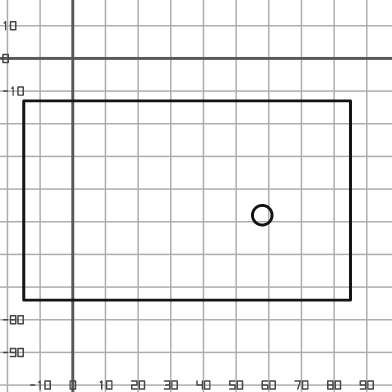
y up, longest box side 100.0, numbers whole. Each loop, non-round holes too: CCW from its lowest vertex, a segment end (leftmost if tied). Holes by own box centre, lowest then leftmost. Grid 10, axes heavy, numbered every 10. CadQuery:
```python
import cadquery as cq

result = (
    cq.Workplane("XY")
    .moveTo(-15.0, -74.0)
    .lineTo(85.0, -74.0)
    .lineTo(85.0, -13.0)
    .lineTo(-15.0, -13.0)
    .close()
    .moveTo(58.0, -48.0)
    .circle(3.0)
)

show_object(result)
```